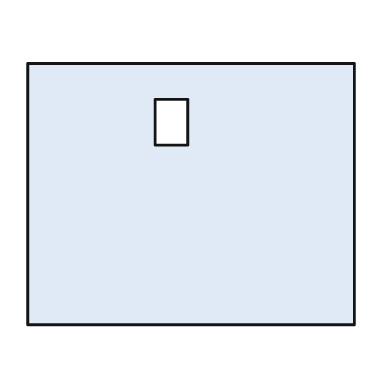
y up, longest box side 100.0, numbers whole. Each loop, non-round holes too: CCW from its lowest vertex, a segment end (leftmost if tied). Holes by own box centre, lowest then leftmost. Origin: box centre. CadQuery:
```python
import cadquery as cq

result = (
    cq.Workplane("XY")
    .moveTo(-50.0, -40.0)
    .lineTo(50.0, -40.0)
    .lineTo(50.0, 40.0)
    .lineTo(-50.0, 40.0)
    .close()
    .moveTo(-11.0, 15.0)
    .lineTo(-1.0, 15.0)
    .lineTo(-1.0, 29.0)
    .lineTo(-11.0, 29.0)
    .close()
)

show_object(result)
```